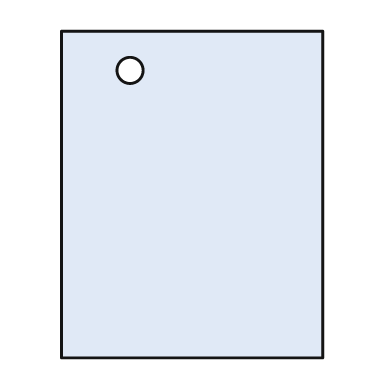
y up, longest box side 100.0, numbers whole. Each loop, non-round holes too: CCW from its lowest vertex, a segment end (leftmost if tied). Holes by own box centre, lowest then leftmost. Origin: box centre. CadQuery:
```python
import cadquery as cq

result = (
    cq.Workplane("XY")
    .moveTo(-40.0, -50.0)
    .lineTo(40.0, -50.0)
    .lineTo(40.0, 50.0)
    .lineTo(-40.0, 50.0)
    .close()
    .moveTo(-19.0, 38.0)
    .circle(4.0)
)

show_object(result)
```